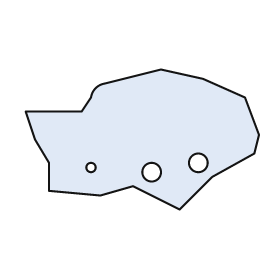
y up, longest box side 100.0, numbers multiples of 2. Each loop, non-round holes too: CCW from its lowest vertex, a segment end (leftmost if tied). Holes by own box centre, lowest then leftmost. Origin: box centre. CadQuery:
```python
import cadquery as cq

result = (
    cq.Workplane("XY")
    .moveTo(16.0, -30.0)
    .lineTo(30.0, -16.0)
    .lineTo(48.0, -6.0)
    .lineTo(50.0, 2.0)
    .lineTo(44.0, 18.0)
    .lineTo(26.0, 26.0)
    .lineTo(8.0, 30.0)
    .lineTo(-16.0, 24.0)
    .threePointArc((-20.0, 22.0), (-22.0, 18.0))
    .lineTo(-26.0, 12.0)
    .lineTo(-50.0, 12.0)
    .lineTo(-46.0, 0.0)
    .lineTo(-40.0, -10.0)
    .lineTo(-40.0, -22.0)
    .lineTo(-18.0, -24.0)
    .lineTo(-4.0, -20.0)
    .close()
    .moveTo(4.0, -14.0)
    .circle(4.0)
    .moveTo(-22.0, -12.0)
    .circle(2.0)
    .moveTo(24.0, -10.0)
    .circle(4.0)
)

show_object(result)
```